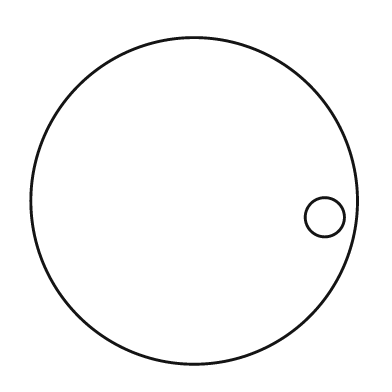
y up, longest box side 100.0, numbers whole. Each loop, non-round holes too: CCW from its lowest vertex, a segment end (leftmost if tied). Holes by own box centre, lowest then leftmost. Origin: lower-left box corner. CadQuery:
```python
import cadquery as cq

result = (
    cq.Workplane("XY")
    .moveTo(50.0, 50.0)
    .circle(50.0)
    .moveTo(90.0, 45.0)
    .circle(6.0)
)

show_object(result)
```